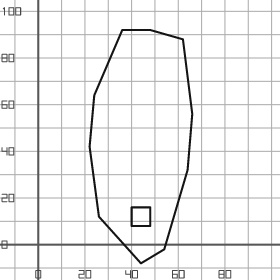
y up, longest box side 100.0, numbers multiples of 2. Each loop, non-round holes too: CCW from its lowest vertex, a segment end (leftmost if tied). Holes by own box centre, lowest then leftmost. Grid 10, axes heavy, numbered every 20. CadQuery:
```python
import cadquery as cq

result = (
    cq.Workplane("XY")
    .moveTo(44.0, -8.0)
    .lineTo(54.0, -2.0)
    .lineTo(64.0, 32.0)
    .lineTo(66.0, 56.0)
    .lineTo(62.0, 88.0)
    .lineTo(48.0, 92.0)
    .lineTo(36.0, 92.0)
    .lineTo(24.0, 64.0)
    .lineTo(22.0, 42.0)
    .lineTo(26.0, 12.0)
    .close()
    .moveTo(40.0, 8.0)
    .lineTo(48.0, 8.0)
    .lineTo(48.0, 16.0)
    .lineTo(40.0, 16.0)
    .close()
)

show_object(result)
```